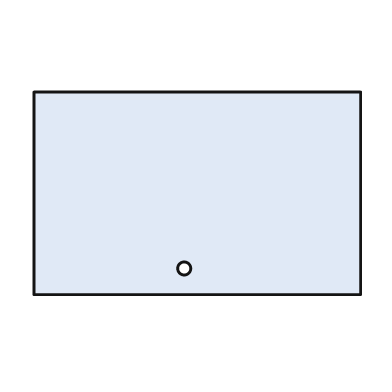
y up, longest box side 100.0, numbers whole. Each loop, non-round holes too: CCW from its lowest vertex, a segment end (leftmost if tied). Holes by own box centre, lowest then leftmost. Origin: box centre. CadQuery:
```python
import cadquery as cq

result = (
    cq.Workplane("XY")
    .moveTo(-50.0, -31.0)
    .lineTo(50.0, -31.0)
    .lineTo(50.0, 31.0)
    .lineTo(-50.0, 31.0)
    .close()
    .moveTo(-4.0, -23.0)
    .circle(2.0)
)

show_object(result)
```